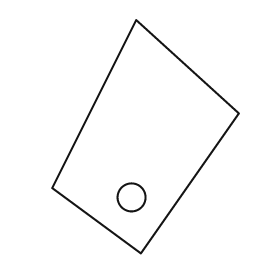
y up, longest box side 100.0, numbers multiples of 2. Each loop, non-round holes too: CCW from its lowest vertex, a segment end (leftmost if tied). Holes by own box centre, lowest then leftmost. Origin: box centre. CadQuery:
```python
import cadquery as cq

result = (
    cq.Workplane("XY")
    .moveTo(-2.0, -50.0)
    .lineTo(40.0, 10.0)
    .lineTo(-4.0, 50.0)
    .lineTo(-40.0, -22.0)
    .close()
    .moveTo(-6.0, -26.0)
    .circle(6.0)
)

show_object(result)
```